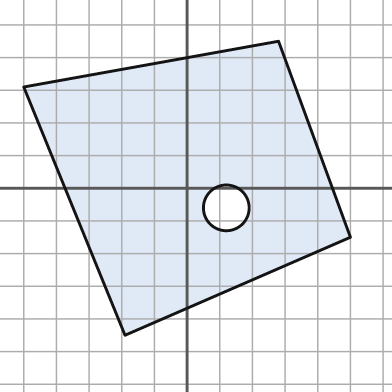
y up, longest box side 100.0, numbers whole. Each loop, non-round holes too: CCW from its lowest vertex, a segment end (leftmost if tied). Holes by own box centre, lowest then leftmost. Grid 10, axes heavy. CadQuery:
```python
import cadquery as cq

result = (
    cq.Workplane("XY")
    .moveTo(-19.0, -45.0)
    .lineTo(50.0, -15.0)
    .lineTo(28.0, 45.0)
    .lineTo(-50.0, 31.0)
    .close()
    .moveTo(12.0, -6.0)
    .circle(7.0)
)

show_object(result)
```